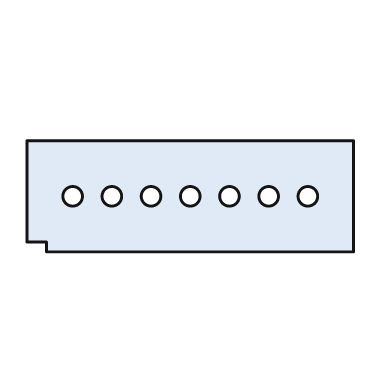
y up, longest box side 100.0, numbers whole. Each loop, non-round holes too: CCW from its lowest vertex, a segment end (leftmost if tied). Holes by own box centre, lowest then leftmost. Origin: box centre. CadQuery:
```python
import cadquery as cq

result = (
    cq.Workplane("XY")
    .moveTo(-44.0, -17.0)
    .lineTo(50.0, -17.0)
    .lineTo(50.0, 17.0)
    .lineTo(-50.0, 17.0)
    .lineTo(-50.0, -14.0)
    .lineTo(-44.0, -14.0)
    .close()
    .moveTo(-36.0, 0.0)
    .circle(3.0)
    .moveTo(-24.0, 0.0)
    .circle(3.0)
    .moveTo(-12.0, 0.0)
    .circle(3.0)
    .moveTo(0.0, 0.0)
    .circle(3.0)
    .moveTo(12.0, 0.0)
    .circle(3.0)
    .moveTo(24.0, 0.0)
    .circle(3.0)
    .moveTo(36.0, 0.0)
    .circle(3.0)
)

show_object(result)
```